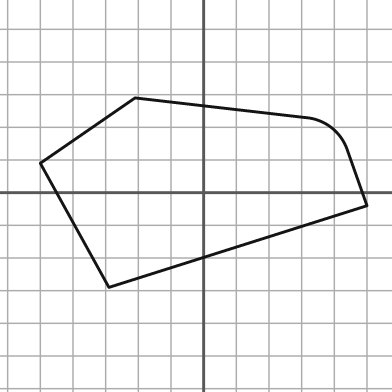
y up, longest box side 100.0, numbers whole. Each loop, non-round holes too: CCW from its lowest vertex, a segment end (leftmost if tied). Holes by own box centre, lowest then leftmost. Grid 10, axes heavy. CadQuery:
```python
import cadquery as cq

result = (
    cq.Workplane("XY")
    .moveTo(-29.0, -29.0)
    .lineTo(50.0, -4.0)
    .lineTo(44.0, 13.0)
    .threePointArc((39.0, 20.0), (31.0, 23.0))
    .lineTo(-21.0, 29.0)
    .lineTo(-50.0, 9.0)
    .close()
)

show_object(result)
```